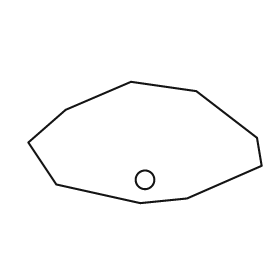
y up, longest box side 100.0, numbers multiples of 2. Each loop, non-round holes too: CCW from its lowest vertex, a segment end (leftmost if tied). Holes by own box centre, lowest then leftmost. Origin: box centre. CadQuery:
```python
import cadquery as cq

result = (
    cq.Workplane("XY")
    .moveTo(-2.0, -26.0)
    .lineTo(18.0, -24.0)
    .lineTo(50.0, -10.0)
    .lineTo(48.0, 2.0)
    .lineTo(22.0, 22.0)
    .lineTo(-6.0, 26.0)
    .lineTo(-34.0, 14.0)
    .lineTo(-50.0, 0.0)
    .lineTo(-38.0, -18.0)
    .close()
    .moveTo(0.0, -16.0)
    .circle(4.0)
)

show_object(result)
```